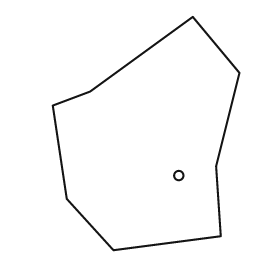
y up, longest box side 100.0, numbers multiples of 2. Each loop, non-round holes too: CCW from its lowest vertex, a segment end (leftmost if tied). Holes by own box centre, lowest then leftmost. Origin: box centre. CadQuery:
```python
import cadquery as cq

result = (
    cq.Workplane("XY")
    .moveTo(-14.0, -50.0)
    .lineTo(32.0, -44.0)
    .lineTo(30.0, -14.0)
    .lineTo(40.0, 26.0)
    .lineTo(20.0, 50.0)
    .lineTo(-24.0, 18.0)
    .lineTo(-40.0, 12.0)
    .lineTo(-34.0, -28.0)
    .close()
    .moveTo(14.0, -18.0)
    .circle(2.0)
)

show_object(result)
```